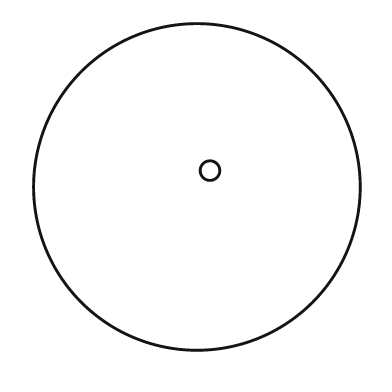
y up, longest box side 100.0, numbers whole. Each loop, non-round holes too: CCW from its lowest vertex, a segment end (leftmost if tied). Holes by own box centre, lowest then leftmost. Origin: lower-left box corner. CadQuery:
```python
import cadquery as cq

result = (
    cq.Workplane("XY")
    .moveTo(50.0, 50.0)
    .circle(50.0)
    .moveTo(54.0, 55.0)
    .circle(3.0)
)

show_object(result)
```